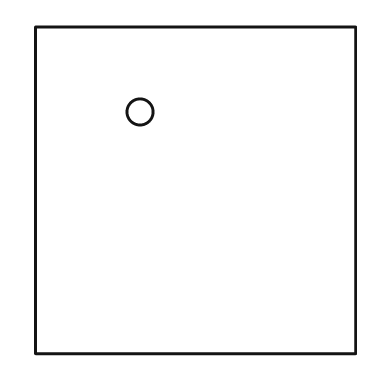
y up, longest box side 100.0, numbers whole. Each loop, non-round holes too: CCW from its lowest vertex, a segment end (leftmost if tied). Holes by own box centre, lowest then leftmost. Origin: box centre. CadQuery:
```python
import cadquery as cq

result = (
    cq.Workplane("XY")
    .moveTo(-49.0, -50.0)
    .lineTo(49.0, -50.0)
    .lineTo(49.0, 50.0)
    .lineTo(-49.0, 50.0)
    .close()
    .moveTo(-17.0, 24.0)
    .circle(4.0)
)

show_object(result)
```